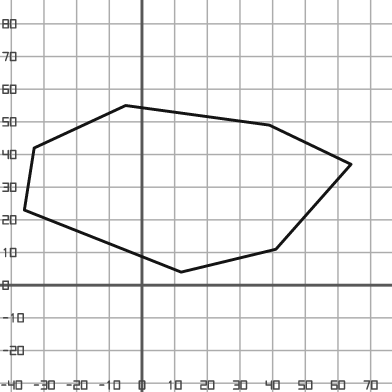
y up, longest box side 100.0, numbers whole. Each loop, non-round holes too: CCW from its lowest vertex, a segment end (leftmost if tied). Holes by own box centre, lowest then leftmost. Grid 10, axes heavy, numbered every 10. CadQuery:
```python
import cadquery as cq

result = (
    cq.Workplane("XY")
    .moveTo(12.0, 4.0)
    .lineTo(41.0, 11.0)
    .lineTo(64.0, 37.0)
    .lineTo(39.0, 49.0)
    .lineTo(-5.0, 55.0)
    .lineTo(-33.0, 42.0)
    .lineTo(-36.0, 23.0)
    .close()
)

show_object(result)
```